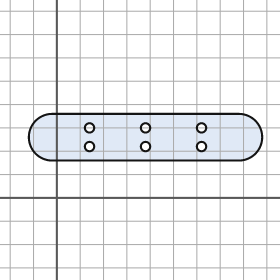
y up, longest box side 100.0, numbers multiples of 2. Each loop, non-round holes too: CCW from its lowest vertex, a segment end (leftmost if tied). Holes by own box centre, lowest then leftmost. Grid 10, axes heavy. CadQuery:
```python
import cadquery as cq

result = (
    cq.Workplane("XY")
    .moveTo(-2.0, 16.0)
    .lineTo(78.0, 16.0)
    .threePointArc((88.0, 26.0), (78.0, 36.0))
    .lineTo(-2.0, 36.0)
    .threePointArc((-12.0, 26.0), (-2.0, 16.0))
    .close()
    .moveTo(14.0, 22.0)
    .circle(2.0)
    .moveTo(38.0, 22.0)
    .circle(2.0)
    .moveTo(62.0, 22.0)
    .circle(2.0)
    .moveTo(14.0, 30.0)
    .circle(2.0)
    .moveTo(38.0, 30.0)
    .circle(2.0)
    .moveTo(62.0, 30.0)
    .circle(2.0)
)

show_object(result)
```